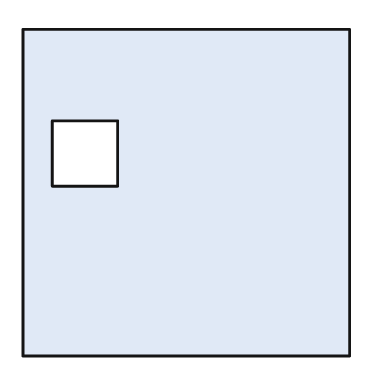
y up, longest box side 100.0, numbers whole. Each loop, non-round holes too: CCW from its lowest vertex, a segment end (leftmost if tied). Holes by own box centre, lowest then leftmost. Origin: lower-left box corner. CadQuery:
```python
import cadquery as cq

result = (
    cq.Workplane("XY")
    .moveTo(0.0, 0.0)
    .lineTo(100.0, 0.0)
    .lineTo(100.0, 100.0)
    .lineTo(0.0, 100.0)
    .close()
    .moveTo(9.0, 52.0)
    .lineTo(29.0, 52.0)
    .lineTo(29.0, 72.0)
    .lineTo(9.0, 72.0)
    .close()
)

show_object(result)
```